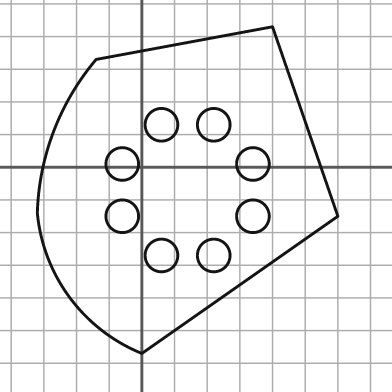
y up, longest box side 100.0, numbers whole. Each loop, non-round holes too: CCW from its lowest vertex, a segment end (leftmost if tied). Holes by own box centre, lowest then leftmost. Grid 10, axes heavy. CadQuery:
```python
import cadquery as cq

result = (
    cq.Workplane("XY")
    .moveTo(0.0, -57.0)
    .lineTo(60.0, -15.0)
    .lineTo(40.0, 43.0)
    .lineTo(-14.0, 33.0)
    .threePointArc((-27.0, 11.0), (-32.0, -14.0))
    .threePointArc((-22.0, -40.0), (0.0, -57.0))
    .close()
    .moveTo(6.0, -27.0)
    .circle(5.0)
    .moveTo(22.0, -27.0)
    .circle(5.0)
    .moveTo(-6.0, -15.0)
    .circle(5.0)
    .moveTo(34.0, -15.0)
    .circle(5.0)
    .moveTo(-6.0, 1.0)
    .circle(5.0)
    .moveTo(34.0, 1.0)
    .circle(5.0)
    .moveTo(6.0, 13.0)
    .circle(5.0)
    .moveTo(22.0, 13.0)
    .circle(5.0)
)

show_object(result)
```